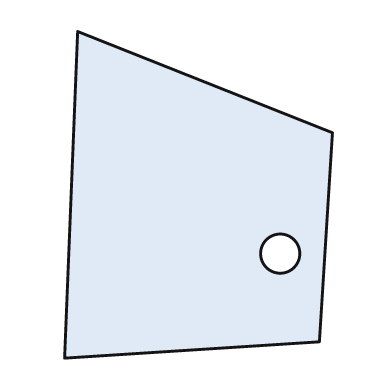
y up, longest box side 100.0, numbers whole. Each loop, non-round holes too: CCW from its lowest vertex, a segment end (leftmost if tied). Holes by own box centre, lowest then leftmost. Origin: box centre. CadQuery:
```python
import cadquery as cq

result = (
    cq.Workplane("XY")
    .moveTo(-41.0, -50.0)
    .lineTo(37.0, -45.0)
    .lineTo(41.0, 19.0)
    .lineTo(-37.0, 50.0)
    .close()
    .moveTo(25.0, -18.0)
    .circle(6.0)
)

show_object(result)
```